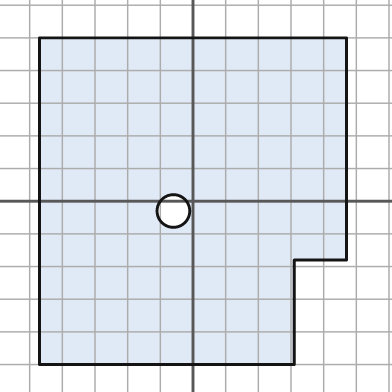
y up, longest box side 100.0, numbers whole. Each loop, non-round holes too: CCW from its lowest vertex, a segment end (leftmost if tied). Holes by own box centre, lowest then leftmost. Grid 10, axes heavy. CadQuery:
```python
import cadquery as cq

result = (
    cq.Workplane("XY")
    .moveTo(-47.0, -50.0)
    .lineTo(31.0, -50.0)
    .lineTo(31.0, -18.0)
    .lineTo(47.0, -18.0)
    .lineTo(47.0, 50.0)
    .lineTo(-47.0, 50.0)
    .close()
    .moveTo(-6.0, -3.0)
    .circle(5.0)
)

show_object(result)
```